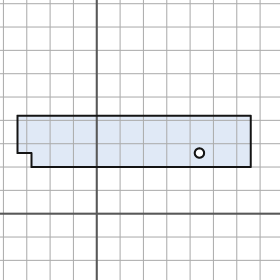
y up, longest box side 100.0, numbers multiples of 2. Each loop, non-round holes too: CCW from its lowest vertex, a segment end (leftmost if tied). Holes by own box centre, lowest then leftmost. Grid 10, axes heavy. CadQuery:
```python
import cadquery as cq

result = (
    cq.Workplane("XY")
    .moveTo(-28.0, 20.0)
    .lineTo(66.0, 20.0)
    .lineTo(66.0, 42.0)
    .lineTo(-34.0, 42.0)
    .lineTo(-34.0, 26.0)
    .lineTo(-28.0, 26.0)
    .close()
    .moveTo(44.0, 26.0)
    .circle(2.0)
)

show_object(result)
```